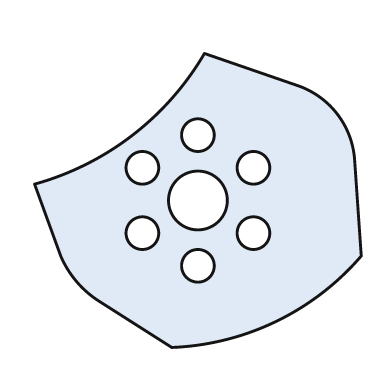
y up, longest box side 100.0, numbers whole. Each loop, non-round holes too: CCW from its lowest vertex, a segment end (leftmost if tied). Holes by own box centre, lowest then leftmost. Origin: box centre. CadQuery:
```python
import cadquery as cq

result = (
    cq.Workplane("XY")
    .moveTo(-8.0, -45.0)
    .threePointArc((24.0, -37.0), (50.0, -17.0))
    .lineTo(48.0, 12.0)
    .threePointArc((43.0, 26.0), (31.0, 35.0))
    .lineTo(2.0, 45.0)
    .threePointArc((-20.0, 20.0), (-50.0, 5.0))
    .lineTo(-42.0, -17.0)
    .threePointArc((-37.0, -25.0), (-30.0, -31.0))
    .close()
    .moveTo(0.0, -20.0)
    .circle(5.0)
    .moveTo(-17.0, -10.0)
    .circle(5.0)
    .moveTo(17.0, -10.0)
    .circle(5.0)
    .moveTo(0.0, 0.0)
    .circle(9.0)
    .moveTo(-17.0, 10.0)
    .circle(5.0)
    .moveTo(17.0, 10.0)
    .circle(5.0)
    .moveTo(0.0, 20.0)
    .circle(5.0)
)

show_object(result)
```